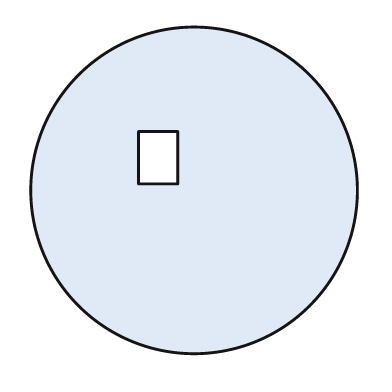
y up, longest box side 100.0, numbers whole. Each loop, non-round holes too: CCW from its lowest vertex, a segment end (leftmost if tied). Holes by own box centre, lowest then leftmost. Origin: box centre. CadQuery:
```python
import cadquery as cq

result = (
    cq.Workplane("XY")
    .moveTo(0.0, 0.0)
    .circle(50.0)
    .moveTo(-17.0, 2.0)
    .lineTo(-5.0, 2.0)
    .lineTo(-5.0, 18.0)
    .lineTo(-17.0, 18.0)
    .close()
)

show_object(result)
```